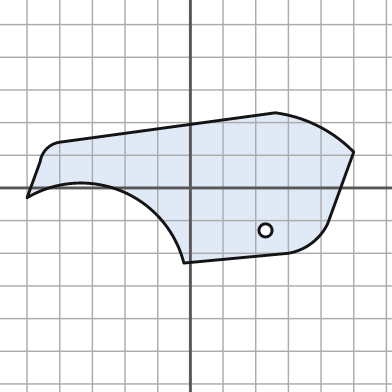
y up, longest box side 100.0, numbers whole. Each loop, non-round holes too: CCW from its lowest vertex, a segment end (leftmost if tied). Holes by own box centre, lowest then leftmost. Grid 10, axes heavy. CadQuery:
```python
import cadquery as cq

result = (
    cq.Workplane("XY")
    .moveTo(-2.0, -23.0)
    .lineTo(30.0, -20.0)
    .threePointArc((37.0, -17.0), (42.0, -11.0))
    .lineTo(50.0, 11.0)
    .threePointArc((39.0, 19.0), (26.0, 23.0))
    .lineTo(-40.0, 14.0)
    .threePointArc((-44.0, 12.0), (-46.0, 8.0))
    .lineTo(-50.0, -3.0)
    .threePointArc((-21.0, -1.0), (-2.0, -23.0))
    .close()
    .moveTo(23.0, -13.0)
    .circle(2.0)
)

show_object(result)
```